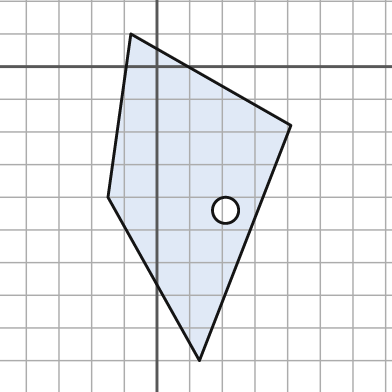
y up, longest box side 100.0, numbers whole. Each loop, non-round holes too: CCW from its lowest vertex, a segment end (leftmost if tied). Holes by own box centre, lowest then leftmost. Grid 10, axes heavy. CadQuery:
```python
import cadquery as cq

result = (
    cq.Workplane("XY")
    .moveTo(13.0, -90.0)
    .lineTo(41.0, -18.0)
    .lineTo(-8.0, 10.0)
    .lineTo(-15.0, -40.0)
    .close()
    .moveTo(21.0, -44.0)
    .circle(4.0)
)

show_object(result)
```